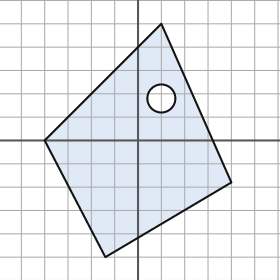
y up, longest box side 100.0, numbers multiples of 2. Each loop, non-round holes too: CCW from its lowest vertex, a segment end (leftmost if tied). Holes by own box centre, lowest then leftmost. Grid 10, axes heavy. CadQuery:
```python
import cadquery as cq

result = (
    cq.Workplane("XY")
    .moveTo(-14.0, -50.0)
    .lineTo(40.0, -18.0)
    .lineTo(10.0, 50.0)
    .lineTo(-40.0, 0.0)
    .close()
    .moveTo(10.0, 18.0)
    .circle(6.0)
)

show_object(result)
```